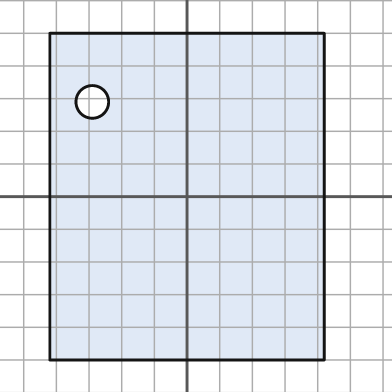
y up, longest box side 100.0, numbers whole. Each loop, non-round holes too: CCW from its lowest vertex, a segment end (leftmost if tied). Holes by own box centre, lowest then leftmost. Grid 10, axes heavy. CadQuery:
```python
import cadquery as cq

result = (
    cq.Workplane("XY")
    .moveTo(-42.0, -50.0)
    .lineTo(42.0, -50.0)
    .lineTo(42.0, 50.0)
    .lineTo(-42.0, 50.0)
    .close()
    .moveTo(-29.0, 29.0)
    .circle(5.0)
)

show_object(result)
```